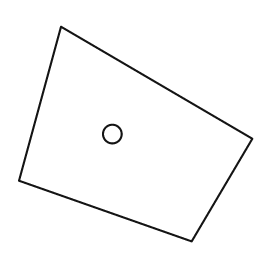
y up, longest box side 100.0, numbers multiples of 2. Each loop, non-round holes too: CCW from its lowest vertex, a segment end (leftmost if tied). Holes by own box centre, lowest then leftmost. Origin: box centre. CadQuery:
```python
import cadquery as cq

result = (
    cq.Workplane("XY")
    .moveTo(24.0, -46.0)
    .lineTo(50.0, -2.0)
    .lineTo(-32.0, 46.0)
    .lineTo(-50.0, -20.0)
    .close()
    .moveTo(-10.0, 0.0)
    .circle(4.0)
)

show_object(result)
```